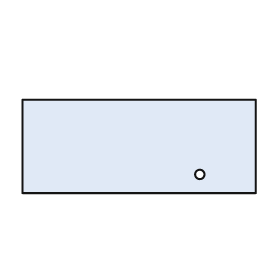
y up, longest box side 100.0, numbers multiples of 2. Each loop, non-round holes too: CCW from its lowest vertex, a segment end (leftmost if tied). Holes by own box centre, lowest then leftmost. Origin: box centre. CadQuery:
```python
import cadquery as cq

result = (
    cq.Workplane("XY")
    .moveTo(-50.0, -20.0)
    .lineTo(50.0, -20.0)
    .lineTo(50.0, 20.0)
    .lineTo(-50.0, 20.0)
    .close()
    .moveTo(26.0, -12.0)
    .circle(2.0)
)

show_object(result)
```